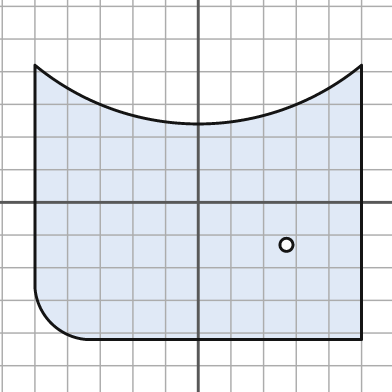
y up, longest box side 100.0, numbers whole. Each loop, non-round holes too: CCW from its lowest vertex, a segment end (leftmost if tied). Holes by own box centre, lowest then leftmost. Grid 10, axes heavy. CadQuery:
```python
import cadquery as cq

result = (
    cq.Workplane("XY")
    .moveTo(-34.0, -42.0)
    .lineTo(50.0, -42.0)
    .lineTo(50.0, 42.0)
    .threePointArc((0.0, 24.0), (-50.0, 42.0))
    .lineTo(-50.0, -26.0)
    .threePointArc((-45.0, -37.0), (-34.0, -42.0))
    .close()
    .moveTo(27.0, -13.0)
    .circle(2.0)
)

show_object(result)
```